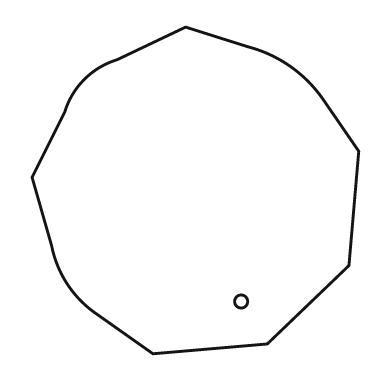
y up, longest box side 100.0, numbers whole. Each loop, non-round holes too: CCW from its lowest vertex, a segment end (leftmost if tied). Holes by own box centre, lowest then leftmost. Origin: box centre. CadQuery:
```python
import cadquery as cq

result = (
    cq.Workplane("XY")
    .moveTo(-13.0, -50.0)
    .lineTo(22.0, -47.0)
    .lineTo(47.0, -23.0)
    .lineTo(50.0, 12.0)
    .lineTo(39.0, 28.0)
    .threePointArc((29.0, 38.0), (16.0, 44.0))
    .lineTo(-3.0, 50.0)
    .lineTo(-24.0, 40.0)
    .threePointArc((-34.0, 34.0), (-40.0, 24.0))
    .lineTo(-50.0, 4.0)
    .lineTo(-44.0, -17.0)
    .threePointArc((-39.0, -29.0), (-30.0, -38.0))
    .close()
    .moveTo(14.0, -34.0)
    .circle(2.0)
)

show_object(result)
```